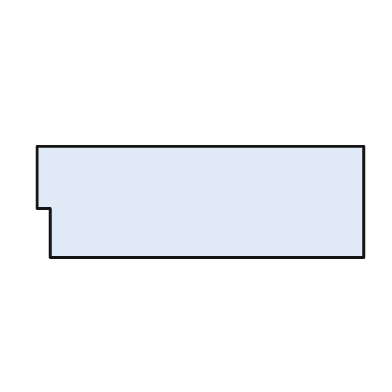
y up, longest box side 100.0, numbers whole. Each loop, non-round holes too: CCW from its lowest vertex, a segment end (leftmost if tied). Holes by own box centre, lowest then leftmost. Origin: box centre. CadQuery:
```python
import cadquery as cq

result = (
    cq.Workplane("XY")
    .moveTo(-46.0, -17.0)
    .lineTo(50.0, -17.0)
    .lineTo(50.0, 17.0)
    .lineTo(-50.0, 17.0)
    .lineTo(-50.0, -2.0)
    .lineTo(-46.0, -2.0)
    .close()
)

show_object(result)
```